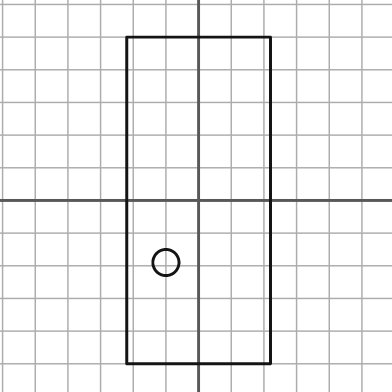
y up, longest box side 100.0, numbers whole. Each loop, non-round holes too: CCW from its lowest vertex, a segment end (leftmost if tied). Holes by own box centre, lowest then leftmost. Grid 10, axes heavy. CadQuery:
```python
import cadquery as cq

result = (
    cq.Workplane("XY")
    .moveTo(-22.0, -50.0)
    .lineTo(22.0, -50.0)
    .lineTo(22.0, 50.0)
    .lineTo(-22.0, 50.0)
    .close()
    .moveTo(-10.0, -19.0)
    .circle(4.0)
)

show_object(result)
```